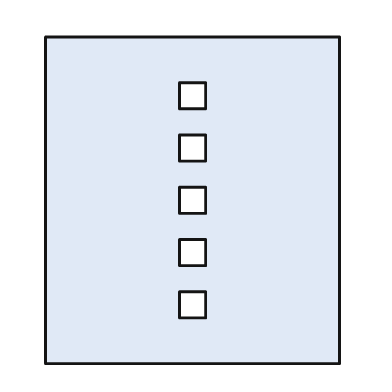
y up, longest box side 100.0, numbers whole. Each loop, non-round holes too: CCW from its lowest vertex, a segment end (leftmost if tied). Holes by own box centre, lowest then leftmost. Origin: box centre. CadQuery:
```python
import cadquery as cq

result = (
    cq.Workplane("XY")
    .moveTo(-45.0, -50.0)
    .lineTo(45.0, -50.0)
    .lineTo(45.0, 50.0)
    .lineTo(-45.0, 50.0)
    .close()
    .moveTo(-4.0, -36.0)
    .lineTo(4.0, -36.0)
    .lineTo(4.0, -28.0)
    .lineTo(-4.0, -28.0)
    .close()
    .moveTo(-4.0, -20.0)
    .lineTo(4.0, -20.0)
    .lineTo(4.0, -12.0)
    .lineTo(-4.0, -12.0)
    .close()
    .moveTo(-4.0, -4.0)
    .lineTo(4.0, -4.0)
    .lineTo(4.0, 4.0)
    .lineTo(-4.0, 4.0)
    .close()
    .moveTo(-4.0, 12.0)
    .lineTo(4.0, 12.0)
    .lineTo(4.0, 20.0)
    .lineTo(-4.0, 20.0)
    .close()
    .moveTo(-4.0, 28.0)
    .lineTo(4.0, 28.0)
    .lineTo(4.0, 36.0)
    .lineTo(-4.0, 36.0)
    .close()
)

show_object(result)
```